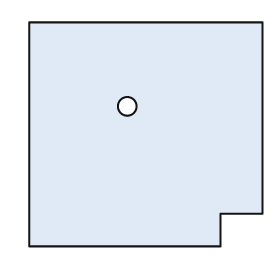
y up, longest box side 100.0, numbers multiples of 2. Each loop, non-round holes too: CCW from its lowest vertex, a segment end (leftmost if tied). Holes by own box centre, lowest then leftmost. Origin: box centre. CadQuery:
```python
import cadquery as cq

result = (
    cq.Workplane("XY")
    .moveTo(-50.0, -48.0)
    .lineTo(32.0, -48.0)
    .lineTo(32.0, -34.0)
    .lineTo(50.0, -34.0)
    .lineTo(50.0, 48.0)
    .lineTo(-50.0, 48.0)
    .close()
    .moveTo(-8.0, 12.0)
    .circle(4.0)
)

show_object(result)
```